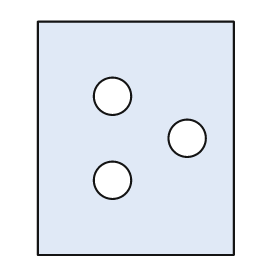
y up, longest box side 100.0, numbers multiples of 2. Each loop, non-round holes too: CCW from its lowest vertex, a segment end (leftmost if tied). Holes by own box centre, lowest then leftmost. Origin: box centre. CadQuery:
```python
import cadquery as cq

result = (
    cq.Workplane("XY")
    .moveTo(-42.0, -50.0)
    .lineTo(42.0, -50.0)
    .lineTo(42.0, 50.0)
    .lineTo(-42.0, 50.0)
    .close()
    .moveTo(-10.0, -18.0)
    .circle(8.0)
    .moveTo(22.0, 0.0)
    .circle(8.0)
    .moveTo(-10.0, 18.0)
    .circle(8.0)
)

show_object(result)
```